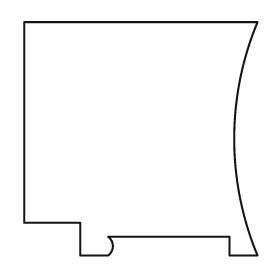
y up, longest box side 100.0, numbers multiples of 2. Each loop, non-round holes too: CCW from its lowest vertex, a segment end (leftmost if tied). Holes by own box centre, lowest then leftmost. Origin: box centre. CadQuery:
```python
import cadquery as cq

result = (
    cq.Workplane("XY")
    .moveTo(-26.0, -50.0)
    .lineTo(-14.0, -50.0)
    .threePointArc((-12.0, -46.0), (-14.0, -42.0))
    .lineTo(38.0, -42.0)
    .lineTo(38.0, -50.0)
    .lineTo(50.0, -50.0)
    .threePointArc((40.0, 0.0), (50.0, 50.0))
    .lineTo(-50.0, 50.0)
    .lineTo(-50.0, -36.0)
    .lineTo(-26.0, -36.0)
    .close()
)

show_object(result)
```